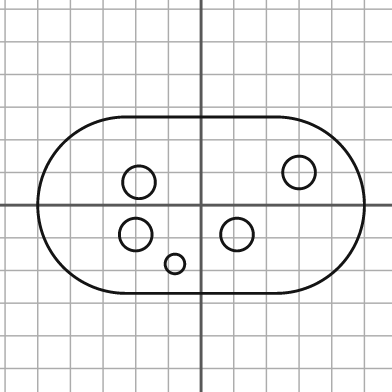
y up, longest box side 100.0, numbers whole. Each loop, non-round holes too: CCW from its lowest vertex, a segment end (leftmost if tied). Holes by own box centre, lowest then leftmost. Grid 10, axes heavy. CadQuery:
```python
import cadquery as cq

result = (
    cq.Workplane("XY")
    .moveTo(-23.0, -27.0)
    .lineTo(23.0, -27.0)
    .threePointArc((50.0, 0.0), (23.0, 27.0))
    .lineTo(-23.0, 27.0)
    .threePointArc((-50.0, 0.0), (-23.0, -27.0))
    .close()
    .moveTo(-8.0, -18.0)
    .circle(3.0)
    .moveTo(-20.0, -9.0)
    .circle(5.0)
    .moveTo(11.0, -9.0)
    .circle(5.0)
    .moveTo(-19.0, 7.0)
    .circle(5.0)
    .moveTo(30.0, 10.0)
    .circle(5.0)
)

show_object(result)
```